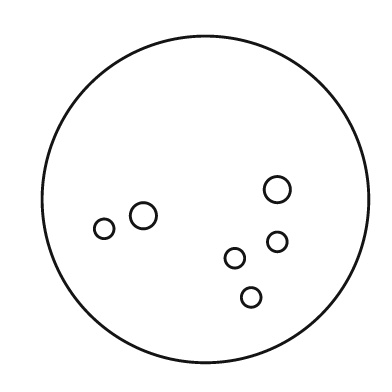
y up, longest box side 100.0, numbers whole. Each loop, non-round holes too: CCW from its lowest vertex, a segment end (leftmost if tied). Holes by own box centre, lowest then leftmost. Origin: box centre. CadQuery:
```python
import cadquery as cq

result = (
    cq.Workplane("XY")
    .moveTo(0.0, 0.0)
    .circle(50.0)
    .moveTo(14.0, -30.0)
    .circle(3.0)
    .moveTo(9.0, -18.0)
    .circle(3.0)
    .moveTo(22.0, -13.0)
    .circle(3.0)
    .moveTo(-31.0, -9.0)
    .circle(3.0)
    .moveTo(-19.0, -5.0)
    .circle(4.0)
    .moveTo(22.0, 3.0)
    .circle(4.0)
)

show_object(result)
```